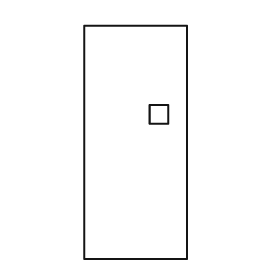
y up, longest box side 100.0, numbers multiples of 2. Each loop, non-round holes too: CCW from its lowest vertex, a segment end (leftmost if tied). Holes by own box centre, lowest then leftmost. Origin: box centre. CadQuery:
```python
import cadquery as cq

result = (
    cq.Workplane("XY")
    .moveTo(-22.0, -50.0)
    .lineTo(22.0, -50.0)
    .lineTo(22.0, 50.0)
    .lineTo(-22.0, 50.0)
    .close()
    .moveTo(6.0, 8.0)
    .lineTo(14.0, 8.0)
    .lineTo(14.0, 16.0)
    .lineTo(6.0, 16.0)
    .close()
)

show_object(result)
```